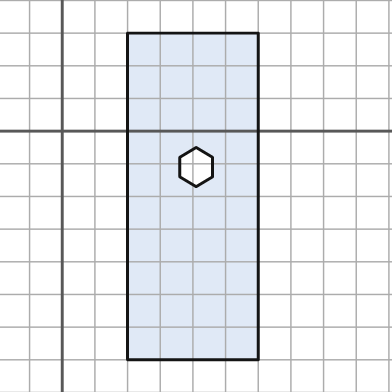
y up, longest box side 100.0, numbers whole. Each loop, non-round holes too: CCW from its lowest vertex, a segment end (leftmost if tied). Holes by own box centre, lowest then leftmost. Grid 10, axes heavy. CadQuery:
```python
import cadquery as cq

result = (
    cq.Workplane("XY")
    .moveTo(20.0, -70.0)
    .lineTo(60.0, -70.0)
    .lineTo(60.0, 30.0)
    .lineTo(20.0, 30.0)
    .close()
    .moveTo(41.0, -17.0)
    .lineTo(46.0, -14.0)
    .lineTo(46.0, -8.0)
    .lineTo(41.0, -5.0)
    .lineTo(36.0, -8.0)
    .lineTo(36.0, -14.0)
    .close()
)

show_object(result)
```